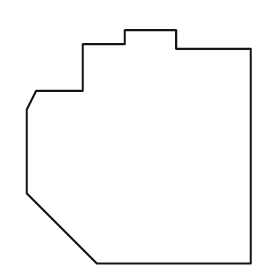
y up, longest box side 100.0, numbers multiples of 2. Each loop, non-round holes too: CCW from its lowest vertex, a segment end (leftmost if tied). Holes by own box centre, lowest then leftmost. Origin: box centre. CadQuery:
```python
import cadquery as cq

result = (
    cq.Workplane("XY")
    .moveTo(-18.0, -50.0)
    .lineTo(48.0, -50.0)
    .lineTo(48.0, 42.0)
    .lineTo(16.0, 42.0)
    .lineTo(16.0, 50.0)
    .lineTo(-6.0, 50.0)
    .lineTo(-6.0, 44.0)
    .lineTo(-24.0, 44.0)
    .lineTo(-24.0, 24.0)
    .lineTo(-44.0, 24.0)
    .lineTo(-48.0, 16.0)
    .lineTo(-48.0, -20.0)
    .close()
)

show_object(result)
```